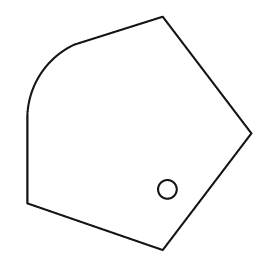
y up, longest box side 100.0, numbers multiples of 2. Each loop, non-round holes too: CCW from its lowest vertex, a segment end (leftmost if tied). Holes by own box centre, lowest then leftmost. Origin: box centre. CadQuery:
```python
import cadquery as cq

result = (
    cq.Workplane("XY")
    .moveTo(10.0, -50.0)
    .lineTo(48.0, 0.0)
    .lineTo(10.0, 50.0)
    .lineTo(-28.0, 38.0)
    .threePointArc((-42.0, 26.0), (-48.0, 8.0))
    .lineTo(-48.0, -30.0)
    .close()
    .moveTo(12.0, -24.0)
    .circle(4.0)
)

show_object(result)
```